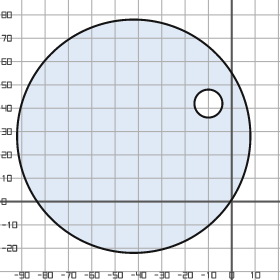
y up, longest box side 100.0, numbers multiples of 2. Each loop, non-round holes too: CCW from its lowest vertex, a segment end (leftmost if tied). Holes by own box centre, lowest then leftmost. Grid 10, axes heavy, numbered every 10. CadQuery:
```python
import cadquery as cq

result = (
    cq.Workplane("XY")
    .moveTo(-42.0, 28.0)
    .circle(50.0)
    .moveTo(-10.0, 42.0)
    .circle(6.0)
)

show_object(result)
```